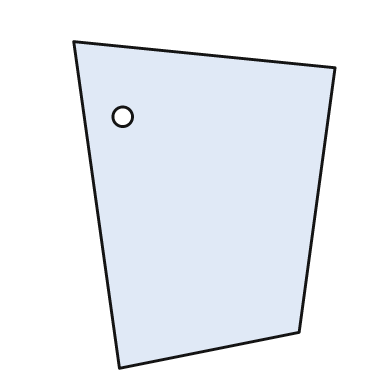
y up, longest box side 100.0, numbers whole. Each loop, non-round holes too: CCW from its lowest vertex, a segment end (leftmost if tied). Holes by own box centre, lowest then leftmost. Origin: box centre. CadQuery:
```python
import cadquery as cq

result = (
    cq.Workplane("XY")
    .moveTo(-26.0, -50.0)
    .lineTo(29.0, -39.0)
    .lineTo(40.0, 42.0)
    .lineTo(-40.0, 50.0)
    .close()
    .moveTo(-25.0, 27.0)
    .circle(3.0)
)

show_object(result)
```